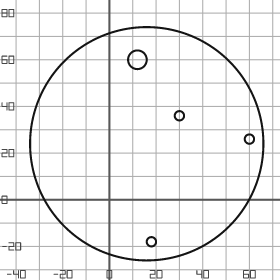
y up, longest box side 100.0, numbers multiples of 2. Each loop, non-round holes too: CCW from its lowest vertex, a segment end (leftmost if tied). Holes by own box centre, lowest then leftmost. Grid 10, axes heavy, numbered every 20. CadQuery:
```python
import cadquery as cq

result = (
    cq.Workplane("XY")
    .moveTo(16.0, 24.0)
    .circle(50.0)
    .moveTo(18.0, -18.0)
    .circle(2.0)
    .moveTo(60.0, 26.0)
    .circle(2.0)
    .moveTo(30.0, 36.0)
    .circle(2.0)
    .moveTo(12.0, 60.0)
    .circle(4.0)
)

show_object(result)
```